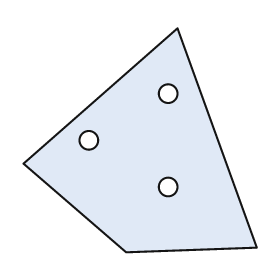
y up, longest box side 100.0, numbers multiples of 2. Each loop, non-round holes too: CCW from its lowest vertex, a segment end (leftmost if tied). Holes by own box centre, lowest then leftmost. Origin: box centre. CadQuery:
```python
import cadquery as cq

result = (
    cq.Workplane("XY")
    .moveTo(-6.0, -48.0)
    .lineTo(50.0, -46.0)
    .lineTo(16.0, 48.0)
    .lineTo(-50.0, -10.0)
    .close()
    .moveTo(12.0, -20.0)
    .circle(4.0)
    .moveTo(-22.0, 0.0)
    .circle(4.0)
    .moveTo(12.0, 20.0)
    .circle(4.0)
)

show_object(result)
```